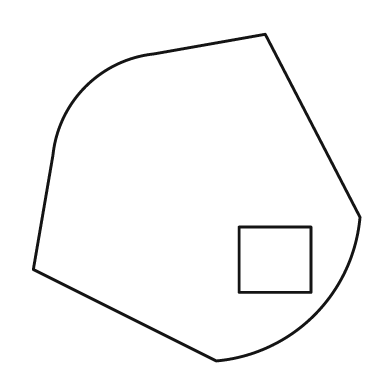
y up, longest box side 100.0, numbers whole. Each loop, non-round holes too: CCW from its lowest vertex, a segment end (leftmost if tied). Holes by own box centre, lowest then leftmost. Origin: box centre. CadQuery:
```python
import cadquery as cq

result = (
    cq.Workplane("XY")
    .moveTo(6.0, -50.0)
    .threePointArc((36.0, -36.0), (50.0, -6.0))
    .lineTo(21.0, 50.0)
    .lineTo(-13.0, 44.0)
    .threePointArc((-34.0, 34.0), (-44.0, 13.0))
    .lineTo(-50.0, -22.0)
    .close()
    .moveTo(13.0, -29.0)
    .lineTo(35.0, -29.0)
    .lineTo(35.0, -9.0)
    .lineTo(13.0, -9.0)
    .close()
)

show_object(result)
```